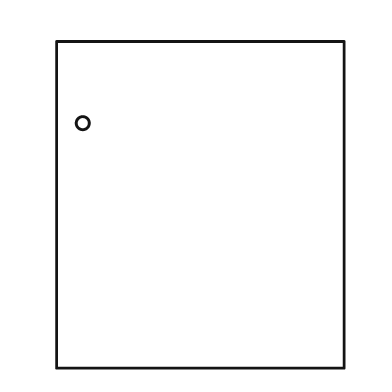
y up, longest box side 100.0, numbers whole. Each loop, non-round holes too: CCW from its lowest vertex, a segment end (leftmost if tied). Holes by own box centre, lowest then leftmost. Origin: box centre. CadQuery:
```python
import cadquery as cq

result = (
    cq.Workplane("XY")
    .moveTo(-44.0, -50.0)
    .lineTo(44.0, -50.0)
    .lineTo(44.0, 50.0)
    .lineTo(-44.0, 50.0)
    .close()
    .moveTo(-36.0, 25.0)
    .circle(2.0)
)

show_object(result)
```